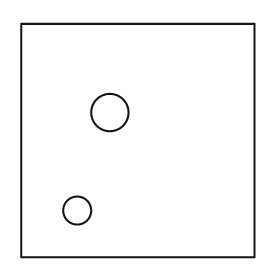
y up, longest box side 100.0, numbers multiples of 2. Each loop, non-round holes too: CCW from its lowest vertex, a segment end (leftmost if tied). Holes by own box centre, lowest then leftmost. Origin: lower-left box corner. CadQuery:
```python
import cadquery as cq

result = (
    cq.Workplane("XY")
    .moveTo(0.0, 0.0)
    .lineTo(100.0, 0.0)
    .lineTo(100.0, 100.0)
    .lineTo(0.0, 100.0)
    .close()
    .moveTo(24.0, 20.0)
    .circle(6.0)
    .moveTo(38.0, 62.0)
    .circle(8.0)
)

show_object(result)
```